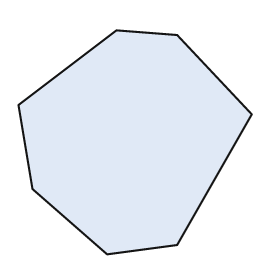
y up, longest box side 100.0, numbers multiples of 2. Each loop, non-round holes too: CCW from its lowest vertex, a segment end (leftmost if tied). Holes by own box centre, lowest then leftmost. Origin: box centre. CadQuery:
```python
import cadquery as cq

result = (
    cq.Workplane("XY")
    .moveTo(-12.0, -48.0)
    .lineTo(18.0, -44.0)
    .lineTo(50.0, 12.0)
    .lineTo(18.0, 46.0)
    .lineTo(-8.0, 48.0)
    .lineTo(-50.0, 16.0)
    .lineTo(-44.0, -20.0)
    .close()
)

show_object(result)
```